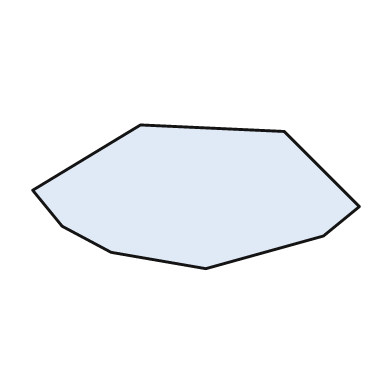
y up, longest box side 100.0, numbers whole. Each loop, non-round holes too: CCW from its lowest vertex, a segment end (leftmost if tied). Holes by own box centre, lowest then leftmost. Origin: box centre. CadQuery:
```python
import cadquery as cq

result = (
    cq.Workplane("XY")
    .moveTo(3.0, -22.0)
    .lineTo(39.0, -12.0)
    .lineTo(50.0, -3.0)
    .lineTo(27.0, 20.0)
    .lineTo(-17.0, 22.0)
    .lineTo(-50.0, 2.0)
    .lineTo(-41.0, -9.0)
    .lineTo(-26.0, -17.0)
    .close()
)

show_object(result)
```